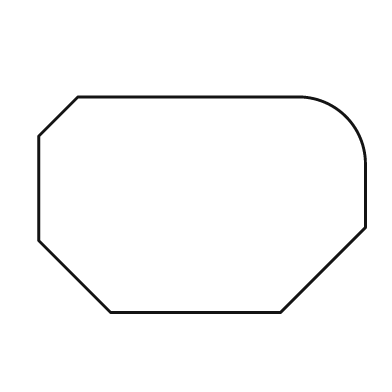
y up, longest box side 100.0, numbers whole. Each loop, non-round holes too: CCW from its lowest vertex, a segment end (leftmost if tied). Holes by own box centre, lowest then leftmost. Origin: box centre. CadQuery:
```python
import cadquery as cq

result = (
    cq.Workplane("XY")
    .moveTo(-28.0, -33.0)
    .lineTo(24.0, -33.0)
    .lineTo(50.0, -7.0)
    .lineTo(50.0, 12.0)
    .threePointArc((44.0, 27.0), (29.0, 33.0))
    .lineTo(-38.0, 33.0)
    .lineTo(-50.0, 21.0)
    .lineTo(-50.0, -11.0)
    .close()
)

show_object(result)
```